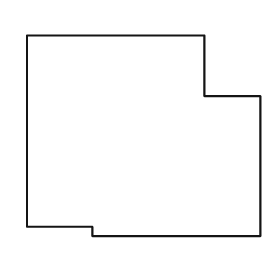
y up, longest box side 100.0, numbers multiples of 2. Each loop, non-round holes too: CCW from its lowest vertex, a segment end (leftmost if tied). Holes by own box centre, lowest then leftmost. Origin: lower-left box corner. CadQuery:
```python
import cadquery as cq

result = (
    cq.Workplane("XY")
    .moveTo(28.0, 0.0)
    .lineTo(100.0, 0.0)
    .lineTo(100.0, 60.0)
    .lineTo(76.0, 60.0)
    .lineTo(76.0, 86.0)
    .lineTo(0.0, 86.0)
    .lineTo(0.0, 4.0)
    .lineTo(28.0, 4.0)
    .close()
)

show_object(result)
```